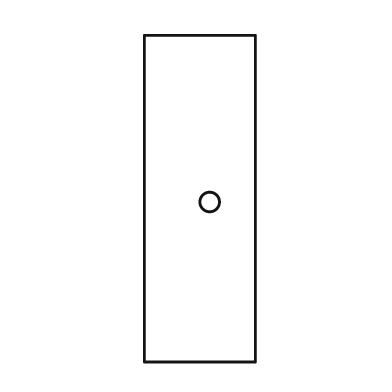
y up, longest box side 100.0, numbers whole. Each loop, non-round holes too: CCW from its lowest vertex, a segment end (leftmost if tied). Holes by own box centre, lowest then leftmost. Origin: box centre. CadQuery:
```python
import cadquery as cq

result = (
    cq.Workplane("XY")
    .moveTo(-17.0, -50.0)
    .lineTo(17.0, -50.0)
    .lineTo(17.0, 50.0)
    .lineTo(-17.0, 50.0)
    .close()
    .moveTo(3.0, -1.0)
    .circle(3.0)
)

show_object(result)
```